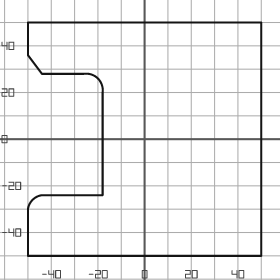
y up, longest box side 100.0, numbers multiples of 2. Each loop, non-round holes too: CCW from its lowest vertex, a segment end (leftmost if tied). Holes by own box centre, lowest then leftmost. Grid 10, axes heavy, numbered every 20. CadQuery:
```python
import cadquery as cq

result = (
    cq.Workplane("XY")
    .moveTo(-50.0, -50.0)
    .lineTo(50.0, -50.0)
    .lineTo(50.0, 50.0)
    .lineTo(-50.0, 50.0)
    .lineTo(-50.0, 36.0)
    .lineTo(-44.0, 28.0)
    .lineTo(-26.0, 28.0)
    .threePointArc((-20.0, 26.0), (-18.0, 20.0))
    .lineTo(-18.0, -24.0)
    .lineTo(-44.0, -24.0)
    .threePointArc((-48.0, -26.0), (-50.0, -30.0))
    .close()
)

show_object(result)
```